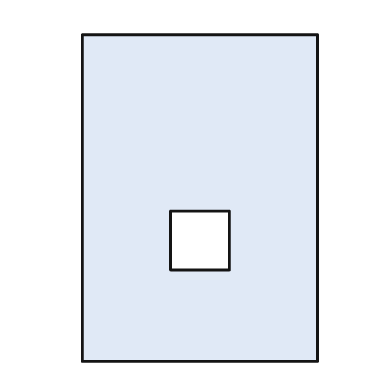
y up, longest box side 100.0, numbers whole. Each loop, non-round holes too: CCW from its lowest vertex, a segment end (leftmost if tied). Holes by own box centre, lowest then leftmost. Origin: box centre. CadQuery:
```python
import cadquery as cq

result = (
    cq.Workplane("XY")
    .moveTo(-36.0, -50.0)
    .lineTo(36.0, -50.0)
    .lineTo(36.0, 50.0)
    .lineTo(-36.0, 50.0)
    .close()
    .moveTo(-9.0, -22.0)
    .lineTo(9.0, -22.0)
    .lineTo(9.0, -4.0)
    .lineTo(-9.0, -4.0)
    .close()
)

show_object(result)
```